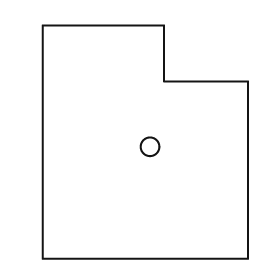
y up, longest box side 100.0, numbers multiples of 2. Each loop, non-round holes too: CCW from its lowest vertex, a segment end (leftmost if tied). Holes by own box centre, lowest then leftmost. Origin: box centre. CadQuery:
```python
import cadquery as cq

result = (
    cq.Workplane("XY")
    .moveTo(-44.0, -50.0)
    .lineTo(44.0, -50.0)
    .lineTo(44.0, 26.0)
    .lineTo(8.0, 26.0)
    .lineTo(8.0, 50.0)
    .lineTo(-44.0, 50.0)
    .close()
    .moveTo(2.0, -2.0)
    .circle(4.0)
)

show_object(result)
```